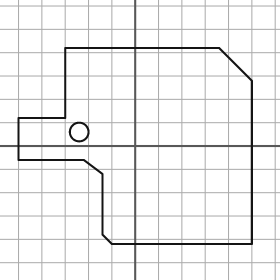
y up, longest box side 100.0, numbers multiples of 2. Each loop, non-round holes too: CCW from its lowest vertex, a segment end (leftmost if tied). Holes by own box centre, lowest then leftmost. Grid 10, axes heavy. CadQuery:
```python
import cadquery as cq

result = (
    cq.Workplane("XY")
    .moveTo(-10.0, -42.0)
    .lineTo(50.0, -42.0)
    .lineTo(50.0, 28.0)
    .lineTo(36.0, 42.0)
    .lineTo(-30.0, 42.0)
    .lineTo(-30.0, 12.0)
    .lineTo(-50.0, 12.0)
    .lineTo(-50.0, -6.0)
    .lineTo(-22.0, -6.0)
    .lineTo(-14.0, -12.0)
    .lineTo(-14.0, -38.0)
    .close()
    .moveTo(-24.0, 6.0)
    .circle(4.0)
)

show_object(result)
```